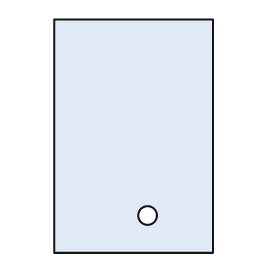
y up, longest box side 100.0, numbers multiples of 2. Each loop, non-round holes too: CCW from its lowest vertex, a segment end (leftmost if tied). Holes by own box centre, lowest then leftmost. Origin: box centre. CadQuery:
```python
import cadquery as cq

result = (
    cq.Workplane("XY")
    .moveTo(-34.0, -50.0)
    .lineTo(34.0, -50.0)
    .lineTo(34.0, 50.0)
    .lineTo(-34.0, 50.0)
    .close()
    .moveTo(6.0, -34.0)
    .circle(4.0)
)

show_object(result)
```